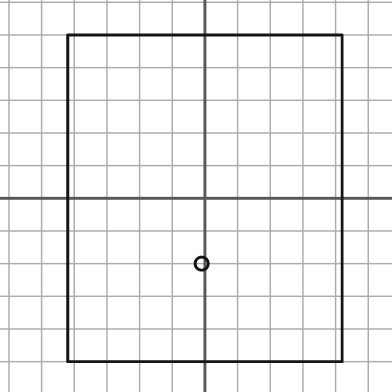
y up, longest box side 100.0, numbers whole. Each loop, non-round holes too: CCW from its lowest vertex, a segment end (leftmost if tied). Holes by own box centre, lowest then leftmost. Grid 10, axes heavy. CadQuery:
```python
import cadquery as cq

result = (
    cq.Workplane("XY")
    .moveTo(-42.0, -50.0)
    .lineTo(42.0, -50.0)
    .lineTo(42.0, 50.0)
    .lineTo(-42.0, 50.0)
    .close()
    .moveTo(-1.0, -20.0)
    .circle(2.0)
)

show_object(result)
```